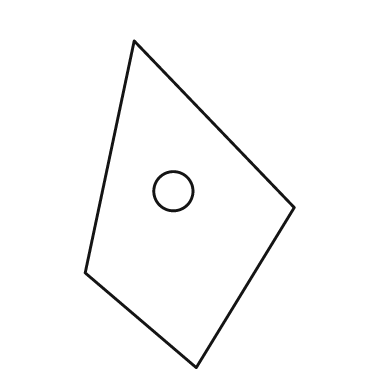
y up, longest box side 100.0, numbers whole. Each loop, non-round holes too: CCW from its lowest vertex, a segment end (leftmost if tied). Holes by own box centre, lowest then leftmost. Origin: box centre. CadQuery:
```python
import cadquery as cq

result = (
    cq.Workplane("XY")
    .moveTo(2.0, -50.0)
    .lineTo(32.0, -1.0)
    .lineTo(-17.0, 50.0)
    .lineTo(-32.0, -21.0)
    .close()
    .moveTo(-5.0, 4.0)
    .circle(6.0)
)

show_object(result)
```